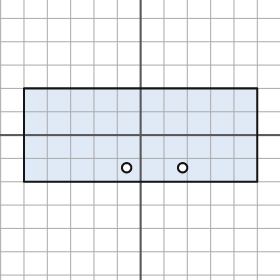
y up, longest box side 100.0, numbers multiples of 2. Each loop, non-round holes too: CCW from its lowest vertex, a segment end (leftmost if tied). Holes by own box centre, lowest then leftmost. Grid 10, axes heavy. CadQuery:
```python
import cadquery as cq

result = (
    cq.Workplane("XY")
    .moveTo(-50.0, -20.0)
    .lineTo(50.0, -20.0)
    .lineTo(50.0, 20.0)
    .lineTo(-50.0, 20.0)
    .close()
    .moveTo(-6.0, -14.0)
    .circle(2.0)
    .moveTo(18.0, -14.0)
    .circle(2.0)
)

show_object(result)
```